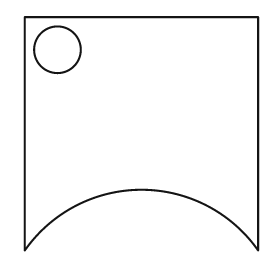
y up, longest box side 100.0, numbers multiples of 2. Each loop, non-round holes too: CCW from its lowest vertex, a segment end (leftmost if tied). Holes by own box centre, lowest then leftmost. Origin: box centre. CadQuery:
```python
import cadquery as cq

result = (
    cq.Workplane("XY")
    .moveTo(-50.0, -50.0)
    .threePointArc((0.0, -24.0), (50.0, -50.0))
    .lineTo(50.0, 50.0)
    .lineTo(-50.0, 50.0)
    .close()
    .moveTo(-36.0, 36.0)
    .circle(10.0)
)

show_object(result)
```